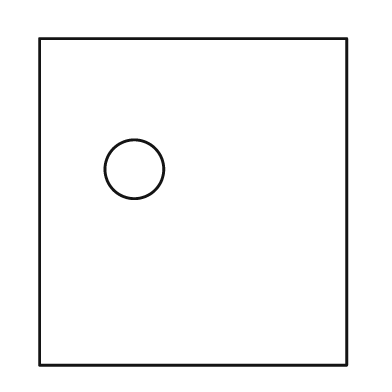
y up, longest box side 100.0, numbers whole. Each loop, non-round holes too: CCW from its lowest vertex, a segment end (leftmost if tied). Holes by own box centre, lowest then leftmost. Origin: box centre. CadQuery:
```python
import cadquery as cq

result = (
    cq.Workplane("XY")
    .moveTo(-47.0, -50.0)
    .lineTo(47.0, -50.0)
    .lineTo(47.0, 50.0)
    .lineTo(-47.0, 50.0)
    .close()
    .moveTo(-18.0, 10.0)
    .circle(9.0)
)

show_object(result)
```